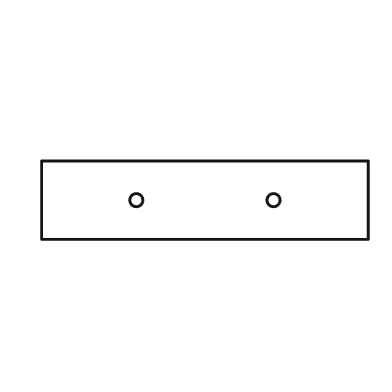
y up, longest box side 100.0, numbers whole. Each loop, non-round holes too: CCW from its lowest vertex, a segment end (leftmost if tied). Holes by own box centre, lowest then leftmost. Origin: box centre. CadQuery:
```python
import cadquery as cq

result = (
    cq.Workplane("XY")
    .moveTo(-50.0, -12.0)
    .lineTo(50.0, -12.0)
    .lineTo(50.0, 12.0)
    .lineTo(-50.0, 12.0)
    .close()
    .moveTo(-21.0, 0.0)
    .circle(2.0)
    .moveTo(21.0, 0.0)
    .circle(2.0)
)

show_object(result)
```